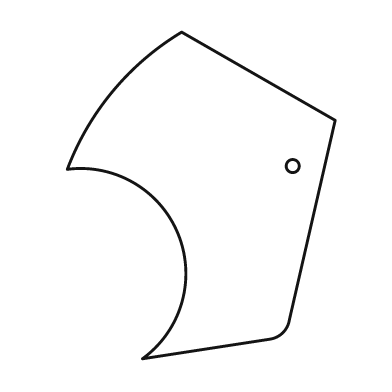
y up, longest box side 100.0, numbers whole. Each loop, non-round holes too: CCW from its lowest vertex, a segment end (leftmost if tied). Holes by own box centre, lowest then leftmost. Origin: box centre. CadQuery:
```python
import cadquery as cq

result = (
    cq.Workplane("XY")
    .moveTo(-18.0, -50.0)
    .lineTo(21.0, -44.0)
    .threePointArc((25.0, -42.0), (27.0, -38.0))
    .lineTo(41.0, 23.0)
    .lineTo(-6.0, 50.0)
    .threePointArc((-27.0, 32.0), (-41.0, 8.0))
    .threePointArc((-7.0, -12.0), (-18.0, -50.0))
    .close()
    .moveTo(28.0, 9.0)
    .circle(2.0)
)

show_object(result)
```